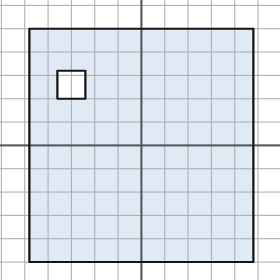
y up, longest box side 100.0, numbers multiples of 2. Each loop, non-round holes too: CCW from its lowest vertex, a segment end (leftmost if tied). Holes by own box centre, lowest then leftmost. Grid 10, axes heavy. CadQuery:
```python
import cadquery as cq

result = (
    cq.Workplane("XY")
    .moveTo(-48.0, -50.0)
    .lineTo(48.0, -50.0)
    .lineTo(48.0, 50.0)
    .lineTo(-48.0, 50.0)
    .close()
    .moveTo(-36.0, 20.0)
    .lineTo(-24.0, 20.0)
    .lineTo(-24.0, 32.0)
    .lineTo(-36.0, 32.0)
    .close()
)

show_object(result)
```